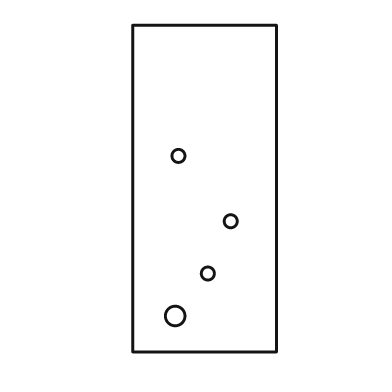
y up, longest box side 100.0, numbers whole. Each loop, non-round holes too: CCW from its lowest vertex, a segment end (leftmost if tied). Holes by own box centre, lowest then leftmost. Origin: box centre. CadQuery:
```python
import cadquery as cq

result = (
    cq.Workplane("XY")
    .moveTo(-22.0, -50.0)
    .lineTo(22.0, -50.0)
    .lineTo(22.0, 50.0)
    .lineTo(-22.0, 50.0)
    .close()
    .moveTo(-9.0, -39.0)
    .circle(3.0)
    .moveTo(1.0, -26.0)
    .circle(2.0)
    .moveTo(8.0, -10.0)
    .circle(2.0)
    .moveTo(-8.0, 10.0)
    .circle(2.0)
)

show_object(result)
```